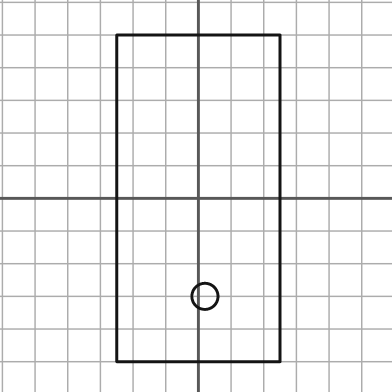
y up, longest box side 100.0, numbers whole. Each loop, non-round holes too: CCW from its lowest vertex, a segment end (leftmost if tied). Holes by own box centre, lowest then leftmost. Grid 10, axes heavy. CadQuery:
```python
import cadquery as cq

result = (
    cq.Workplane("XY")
    .moveTo(-25.0, -50.0)
    .lineTo(25.0, -50.0)
    .lineTo(25.0, 50.0)
    .lineTo(-25.0, 50.0)
    .close()
    .moveTo(2.0, -30.0)
    .circle(4.0)
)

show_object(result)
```